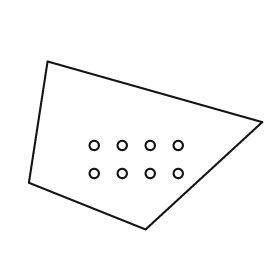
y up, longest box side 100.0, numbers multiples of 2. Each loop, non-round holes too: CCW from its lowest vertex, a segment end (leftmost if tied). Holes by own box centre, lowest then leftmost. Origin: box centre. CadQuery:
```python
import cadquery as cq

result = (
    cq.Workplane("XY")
    .moveTo(0.0, -36.0)
    .lineTo(50.0, 10.0)
    .lineTo(-42.0, 36.0)
    .lineTo(-50.0, -16.0)
    .close()
    .moveTo(-22.0, -12.0)
    .circle(2.0)
    .moveTo(-10.0, -12.0)
    .circle(2.0)
    .moveTo(2.0, -12.0)
    .circle(2.0)
    .moveTo(14.0, -12.0)
    .circle(2.0)
    .moveTo(-22.0, 0.0)
    .circle(2.0)
    .moveTo(-10.0, 0.0)
    .circle(2.0)
    .moveTo(2.0, 0.0)
    .circle(2.0)
    .moveTo(14.0, 0.0)
    .circle(2.0)
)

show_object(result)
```